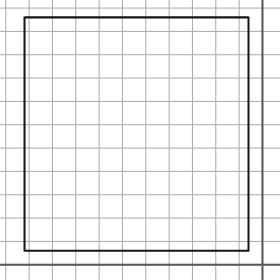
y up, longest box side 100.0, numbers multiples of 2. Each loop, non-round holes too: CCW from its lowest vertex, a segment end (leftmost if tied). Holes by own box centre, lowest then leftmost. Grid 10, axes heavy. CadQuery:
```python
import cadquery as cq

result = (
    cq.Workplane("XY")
    .moveTo(-102.0, 6.0)
    .lineTo(-6.0, 6.0)
    .lineTo(-6.0, 106.0)
    .lineTo(-102.0, 106.0)
    .close()
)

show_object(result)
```